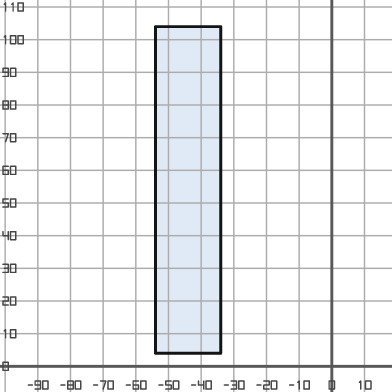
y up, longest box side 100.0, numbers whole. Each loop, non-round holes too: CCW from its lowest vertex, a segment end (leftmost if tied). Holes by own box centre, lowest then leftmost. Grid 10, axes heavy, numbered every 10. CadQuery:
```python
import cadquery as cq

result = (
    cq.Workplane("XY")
    .moveTo(-54.0, 4.0)
    .lineTo(-34.0, 4.0)
    .lineTo(-34.0, 104.0)
    .lineTo(-54.0, 104.0)
    .close()
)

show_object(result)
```